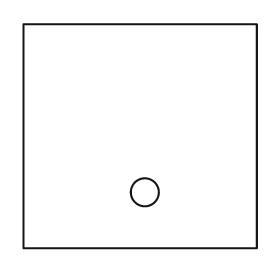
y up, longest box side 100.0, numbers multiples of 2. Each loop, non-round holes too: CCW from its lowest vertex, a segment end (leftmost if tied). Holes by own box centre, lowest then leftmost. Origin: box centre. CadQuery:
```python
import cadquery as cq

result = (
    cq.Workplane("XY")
    .moveTo(-50.0, -48.0)
    .lineTo(50.0, -48.0)
    .lineTo(50.0, 48.0)
    .lineTo(-50.0, 48.0)
    .close()
    .moveTo(2.0, -24.0)
    .circle(6.0)
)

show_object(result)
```